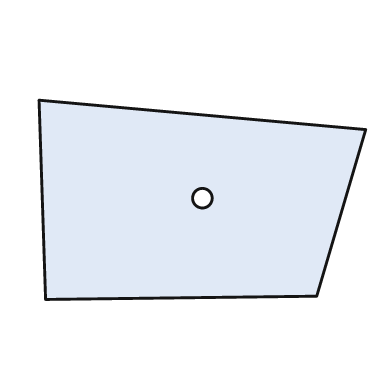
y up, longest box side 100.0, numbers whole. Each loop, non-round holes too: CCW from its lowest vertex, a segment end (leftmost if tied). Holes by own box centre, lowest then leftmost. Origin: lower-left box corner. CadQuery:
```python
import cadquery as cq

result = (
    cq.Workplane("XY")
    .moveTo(2.0, 0.0)
    .lineTo(85.0, 1.0)
    .lineTo(100.0, 52.0)
    .lineTo(0.0, 61.0)
    .close()
    .moveTo(50.0, 31.0)
    .circle(3.0)
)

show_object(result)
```